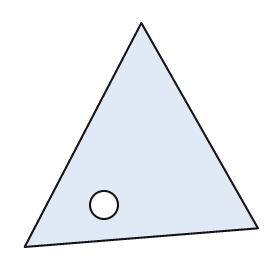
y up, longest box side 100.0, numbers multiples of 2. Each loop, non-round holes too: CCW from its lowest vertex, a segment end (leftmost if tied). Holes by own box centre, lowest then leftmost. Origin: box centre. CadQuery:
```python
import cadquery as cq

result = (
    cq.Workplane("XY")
    .moveTo(-50.0, -48.0)
    .lineTo(50.0, -40.0)
    .lineTo(0.0, 48.0)
    .close()
    .moveTo(-16.0, -30.0)
    .circle(6.0)
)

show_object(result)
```